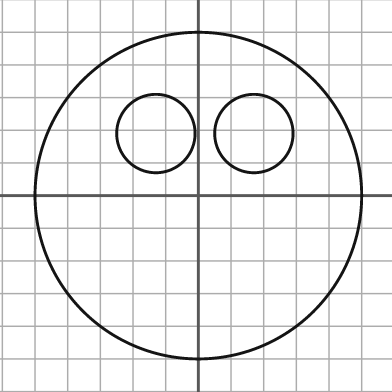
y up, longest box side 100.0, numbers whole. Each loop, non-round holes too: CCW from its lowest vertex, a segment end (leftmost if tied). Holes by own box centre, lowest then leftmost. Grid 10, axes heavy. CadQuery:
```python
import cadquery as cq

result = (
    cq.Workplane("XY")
    .moveTo(0.0, 0.0)
    .circle(50.0)
    .moveTo(-13.0, 19.0)
    .circle(12.0)
    .moveTo(17.0, 19.0)
    .circle(12.0)
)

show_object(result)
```